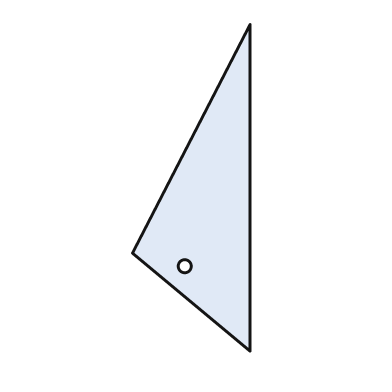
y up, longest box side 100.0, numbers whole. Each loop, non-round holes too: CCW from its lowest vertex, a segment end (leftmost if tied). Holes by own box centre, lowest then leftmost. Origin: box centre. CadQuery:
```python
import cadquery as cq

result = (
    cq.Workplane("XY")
    .moveTo(18.0, -50.0)
    .lineTo(18.0, 50.0)
    .lineTo(-18.0, -20.0)
    .close()
    .moveTo(-2.0, -24.0)
    .circle(2.0)
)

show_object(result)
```